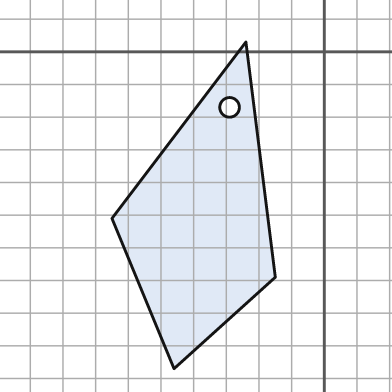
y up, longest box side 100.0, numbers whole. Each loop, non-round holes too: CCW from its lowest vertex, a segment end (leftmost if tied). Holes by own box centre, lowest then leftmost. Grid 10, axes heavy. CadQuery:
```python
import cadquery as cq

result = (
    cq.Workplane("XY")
    .moveTo(-46.0, -97.0)
    .lineTo(-15.0, -69.0)
    .lineTo(-24.0, 3.0)
    .lineTo(-65.0, -51.0)
    .close()
    .moveTo(-29.0, -17.0)
    .circle(3.0)
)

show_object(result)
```